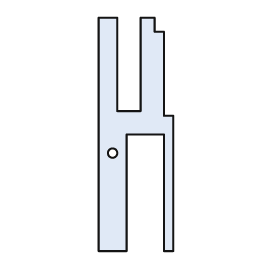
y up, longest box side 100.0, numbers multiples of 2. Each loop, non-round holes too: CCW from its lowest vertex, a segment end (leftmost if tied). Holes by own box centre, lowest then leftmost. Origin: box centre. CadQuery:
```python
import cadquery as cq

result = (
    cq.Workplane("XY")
    .moveTo(-16.0, -50.0)
    .lineTo(-4.0, -50.0)
    .lineTo(-4.0, 0.0)
    .lineTo(12.0, 0.0)
    .lineTo(12.0, -50.0)
    .lineTo(16.0, -50.0)
    .lineTo(16.0, 8.0)
    .lineTo(12.0, 8.0)
    .lineTo(12.0, 44.0)
    .lineTo(8.0, 44.0)
    .lineTo(8.0, 50.0)
    .lineTo(2.0, 50.0)
    .lineTo(2.0, 10.0)
    .lineTo(-8.0, 10.0)
    .lineTo(-8.0, 50.0)
    .lineTo(-16.0, 50.0)
    .close()
    .moveTo(-10.0, -8.0)
    .circle(2.0)
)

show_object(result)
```